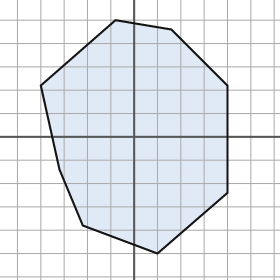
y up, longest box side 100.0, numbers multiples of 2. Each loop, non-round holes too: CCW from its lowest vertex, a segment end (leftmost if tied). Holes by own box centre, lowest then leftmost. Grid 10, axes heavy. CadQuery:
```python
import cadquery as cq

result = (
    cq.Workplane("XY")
    .moveTo(10.0, -50.0)
    .lineTo(40.0, -24.0)
    .lineTo(40.0, 22.0)
    .lineTo(16.0, 46.0)
    .lineTo(-8.0, 50.0)
    .lineTo(-40.0, 22.0)
    .lineTo(-32.0, -14.0)
    .lineTo(-22.0, -38.0)
    .close()
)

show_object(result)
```